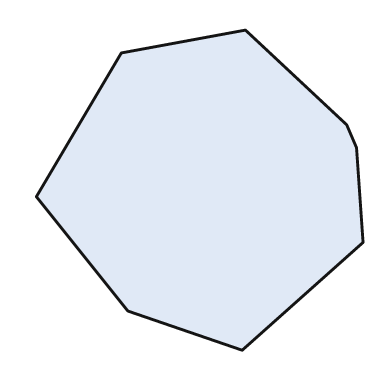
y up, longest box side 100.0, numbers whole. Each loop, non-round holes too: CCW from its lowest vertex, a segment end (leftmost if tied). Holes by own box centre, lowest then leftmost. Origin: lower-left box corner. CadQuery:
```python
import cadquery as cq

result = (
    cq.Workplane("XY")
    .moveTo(63.0, 0.0)
    .lineTo(100.0, 33.0)
    .lineTo(98.0, 62.0)
    .lineTo(95.0, 69.0)
    .lineTo(64.0, 98.0)
    .lineTo(26.0, 91.0)
    .lineTo(0.0, 47.0)
    .lineTo(28.0, 12.0)
    .close()
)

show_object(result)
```